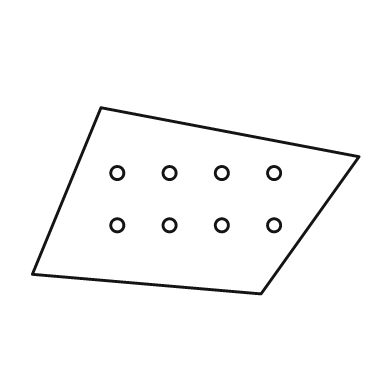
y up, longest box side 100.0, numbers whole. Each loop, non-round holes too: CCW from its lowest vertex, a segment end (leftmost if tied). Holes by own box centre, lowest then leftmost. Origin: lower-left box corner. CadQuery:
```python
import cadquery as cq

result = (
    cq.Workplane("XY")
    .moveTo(70.0, 0.0)
    .lineTo(100.0, 42.0)
    .lineTo(21.0, 57.0)
    .lineTo(0.0, 6.0)
    .close()
    .moveTo(26.0, 21.0)
    .circle(2.0)
    .moveTo(42.0, 21.0)
    .circle(2.0)
    .moveTo(58.0, 21.0)
    .circle(2.0)
    .moveTo(74.0, 21.0)
    .circle(2.0)
    .moveTo(26.0, 37.0)
    .circle(2.0)
    .moveTo(42.0, 37.0)
    .circle(2.0)
    .moveTo(58.0, 37.0)
    .circle(2.0)
    .moveTo(74.0, 37.0)
    .circle(2.0)
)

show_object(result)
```